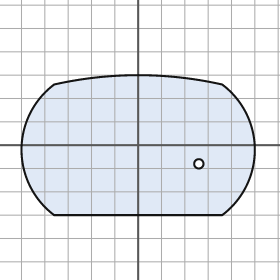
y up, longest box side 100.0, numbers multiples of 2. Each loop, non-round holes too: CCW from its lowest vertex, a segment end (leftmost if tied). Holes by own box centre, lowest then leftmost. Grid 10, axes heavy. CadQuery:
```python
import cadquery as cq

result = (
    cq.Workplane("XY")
    .moveTo(-36.0, -30.0)
    .lineTo(36.0, -30.0)
    .threePointArc((50.0, -2.0), (36.0, 26.0))
    .threePointArc((0.0, 30.0), (-36.0, 26.0))
    .threePointArc((-50.0, -2.0), (-36.0, -30.0))
    .close()
    .moveTo(26.0, -8.0)
    .circle(2.0)
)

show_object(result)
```